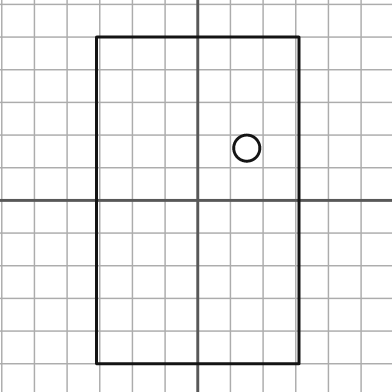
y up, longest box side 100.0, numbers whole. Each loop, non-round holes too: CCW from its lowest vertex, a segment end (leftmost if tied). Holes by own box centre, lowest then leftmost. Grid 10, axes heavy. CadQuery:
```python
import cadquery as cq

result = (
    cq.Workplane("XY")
    .moveTo(-31.0, -50.0)
    .lineTo(31.0, -50.0)
    .lineTo(31.0, 50.0)
    .lineTo(-31.0, 50.0)
    .close()
    .moveTo(15.0, 16.0)
    .circle(4.0)
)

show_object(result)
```